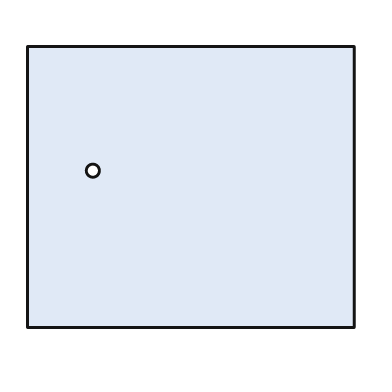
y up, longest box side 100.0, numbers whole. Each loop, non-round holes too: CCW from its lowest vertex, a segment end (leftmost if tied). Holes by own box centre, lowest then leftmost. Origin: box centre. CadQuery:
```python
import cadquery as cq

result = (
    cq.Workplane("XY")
    .moveTo(-50.0, -43.0)
    .lineTo(50.0, -43.0)
    .lineTo(50.0, 43.0)
    .lineTo(-50.0, 43.0)
    .close()
    .moveTo(-30.0, 5.0)
    .circle(2.0)
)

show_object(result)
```